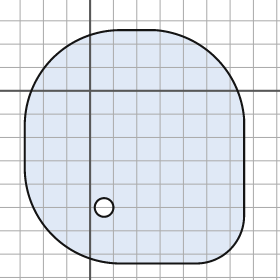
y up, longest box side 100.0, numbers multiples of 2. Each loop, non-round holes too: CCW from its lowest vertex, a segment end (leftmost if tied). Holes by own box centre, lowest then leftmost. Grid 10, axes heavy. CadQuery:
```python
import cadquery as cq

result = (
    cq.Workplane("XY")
    .moveTo(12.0, -74.0)
    .lineTo(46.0, -74.0)
    .threePointArc((60.0, -68.0), (66.0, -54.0))
    .lineTo(66.0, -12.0)
    .threePointArc((54.0, 14.0), (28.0, 26.0))
    .lineTo(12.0, 26.0)
    .threePointArc((-16.0, 14.0), (-28.0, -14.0))
    .lineTo(-28.0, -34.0)
    .threePointArc((-16.0, -62.0), (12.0, -74.0))
    .close()
    .moveTo(6.0, -50.0)
    .circle(4.0)
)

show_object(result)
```